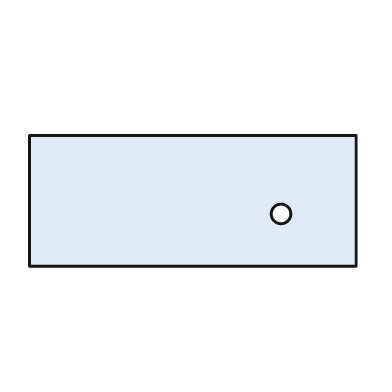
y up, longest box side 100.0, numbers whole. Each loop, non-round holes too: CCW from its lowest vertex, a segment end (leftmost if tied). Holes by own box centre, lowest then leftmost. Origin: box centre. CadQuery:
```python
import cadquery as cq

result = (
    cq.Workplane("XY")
    .moveTo(-50.0, -20.0)
    .lineTo(50.0, -20.0)
    .lineTo(50.0, 20.0)
    .lineTo(-50.0, 20.0)
    .close()
    .moveTo(27.0, -4.0)
    .circle(3.0)
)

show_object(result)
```